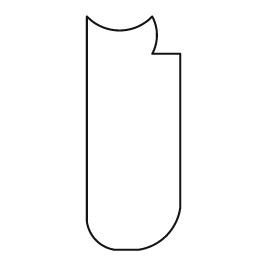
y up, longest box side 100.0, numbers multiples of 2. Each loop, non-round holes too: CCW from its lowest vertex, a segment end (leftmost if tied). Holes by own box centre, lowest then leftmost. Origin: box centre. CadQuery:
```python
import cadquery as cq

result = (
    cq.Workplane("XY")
    .moveTo(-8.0, -50.0)
    .lineTo(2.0, -50.0)
    .threePointArc((14.0, -44.0), (20.0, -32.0))
    .lineTo(20.0, 34.0)
    .lineTo(8.0, 34.0)
    .threePointArc((10.0, 42.0), (8.0, 50.0))
    .threePointArc((-6.0, 44.0), (-20.0, 50.0))
    .lineTo(-20.0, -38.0)
    .threePointArc((-16.0, -46.0), (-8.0, -50.0))
    .close()
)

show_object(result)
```